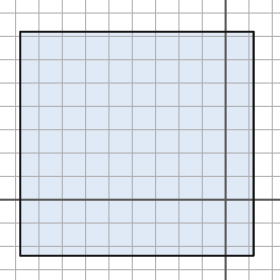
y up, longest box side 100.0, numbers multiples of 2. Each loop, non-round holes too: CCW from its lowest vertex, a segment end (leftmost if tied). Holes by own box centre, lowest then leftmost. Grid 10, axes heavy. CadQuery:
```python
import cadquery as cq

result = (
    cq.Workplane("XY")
    .moveTo(-88.0, -24.0)
    .lineTo(12.0, -24.0)
    .lineTo(12.0, 72.0)
    .lineTo(-88.0, 72.0)
    .close()
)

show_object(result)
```